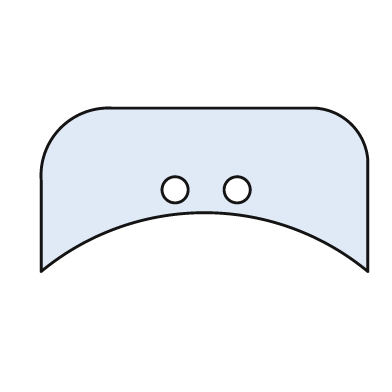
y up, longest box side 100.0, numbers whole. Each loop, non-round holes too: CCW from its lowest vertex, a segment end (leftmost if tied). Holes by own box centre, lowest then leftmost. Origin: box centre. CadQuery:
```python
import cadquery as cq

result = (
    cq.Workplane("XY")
    .moveTo(-50.0, -25.0)
    .threePointArc((0.0, -7.0), (50.0, -25.0))
    .lineTo(50.0, 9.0)
    .threePointArc((45.0, 20.0), (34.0, 25.0))
    .lineTo(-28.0, 25.0)
    .threePointArc((-44.0, 19.0), (-50.0, 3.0))
    .close()
    .moveTo(-9.0, 0.0)
    .circle(4.0)
    .moveTo(10.0, 0.0)
    .circle(4.0)
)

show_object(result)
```